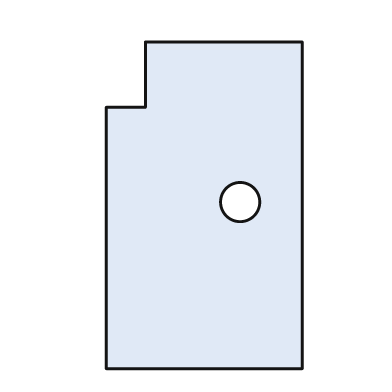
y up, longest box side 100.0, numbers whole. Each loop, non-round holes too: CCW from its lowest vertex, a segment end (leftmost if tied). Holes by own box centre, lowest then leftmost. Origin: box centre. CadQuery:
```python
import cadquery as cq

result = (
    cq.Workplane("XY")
    .moveTo(-30.0, -50.0)
    .lineTo(30.0, -50.0)
    .lineTo(30.0, 50.0)
    .lineTo(-18.0, 50.0)
    .lineTo(-18.0, 30.0)
    .lineTo(-30.0, 30.0)
    .close()
    .moveTo(11.0, 1.0)
    .circle(6.0)
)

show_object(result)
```